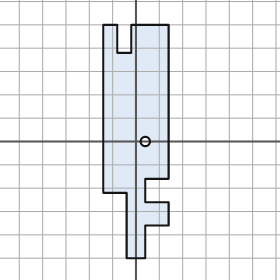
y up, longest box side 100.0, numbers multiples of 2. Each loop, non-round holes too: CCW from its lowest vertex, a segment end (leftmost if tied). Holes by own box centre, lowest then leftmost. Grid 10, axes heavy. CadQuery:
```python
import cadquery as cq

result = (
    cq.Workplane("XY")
    .moveTo(-4.0, -50.0)
    .lineTo(4.0, -50.0)
    .lineTo(4.0, -36.0)
    .lineTo(14.0, -36.0)
    .lineTo(14.0, -26.0)
    .lineTo(4.0, -26.0)
    .lineTo(4.0, -16.0)
    .lineTo(14.0, -16.0)
    .lineTo(14.0, 50.0)
    .lineTo(-2.0, 50.0)
    .lineTo(-2.0, 38.0)
    .lineTo(-8.0, 38.0)
    .lineTo(-8.0, 50.0)
    .lineTo(-14.0, 50.0)
    .lineTo(-14.0, -22.0)
    .lineTo(-4.0, -22.0)
    .close()
    .moveTo(4.0, 0.0)
    .circle(2.0)
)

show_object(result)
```